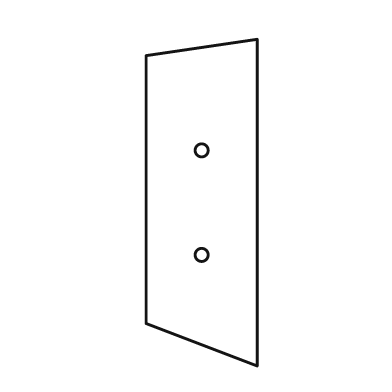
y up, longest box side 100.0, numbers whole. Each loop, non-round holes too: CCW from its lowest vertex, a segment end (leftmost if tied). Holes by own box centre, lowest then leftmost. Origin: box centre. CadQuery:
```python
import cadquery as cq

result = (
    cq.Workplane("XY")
    .moveTo(17.0, -50.0)
    .lineTo(17.0, 50.0)
    .lineTo(-17.0, 45.0)
    .lineTo(-17.0, -37.0)
    .close()
    .moveTo(0.0, -16.0)
    .circle(2.0)
    .moveTo(0.0, 16.0)
    .circle(2.0)
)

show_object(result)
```